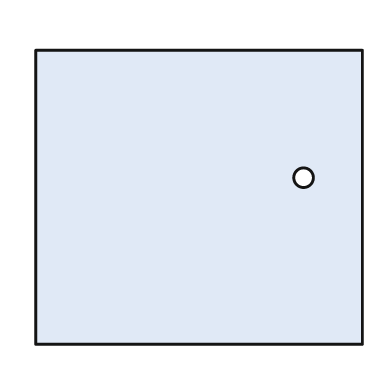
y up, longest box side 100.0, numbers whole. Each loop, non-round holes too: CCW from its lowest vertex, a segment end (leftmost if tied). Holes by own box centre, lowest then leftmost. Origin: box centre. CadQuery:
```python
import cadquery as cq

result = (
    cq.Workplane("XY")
    .moveTo(-50.0, -45.0)
    .lineTo(50.0, -45.0)
    .lineTo(50.0, 45.0)
    .lineTo(-50.0, 45.0)
    .close()
    .moveTo(32.0, 6.0)
    .circle(3.0)
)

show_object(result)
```